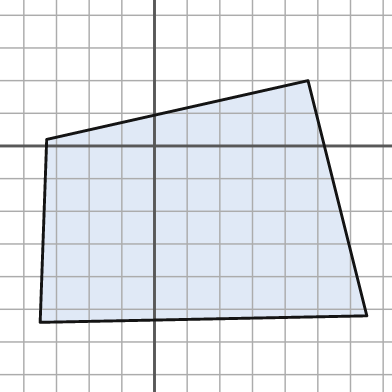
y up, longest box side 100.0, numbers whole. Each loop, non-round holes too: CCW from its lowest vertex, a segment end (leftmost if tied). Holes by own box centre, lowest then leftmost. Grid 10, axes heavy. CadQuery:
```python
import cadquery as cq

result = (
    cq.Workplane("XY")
    .moveTo(-35.0, -54.0)
    .lineTo(65.0, -52.0)
    .lineTo(47.0, 20.0)
    .lineTo(-33.0, 2.0)
    .close()
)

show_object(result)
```